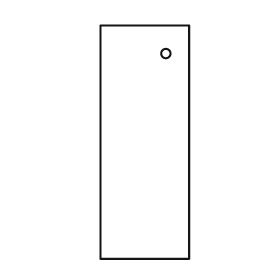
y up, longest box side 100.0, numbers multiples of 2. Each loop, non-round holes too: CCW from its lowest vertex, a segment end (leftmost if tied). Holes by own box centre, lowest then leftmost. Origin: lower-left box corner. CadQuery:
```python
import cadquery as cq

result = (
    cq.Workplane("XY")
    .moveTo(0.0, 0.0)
    .lineTo(38.0, 0.0)
    .lineTo(38.0, 100.0)
    .lineTo(0.0, 100.0)
    .close()
    .moveTo(28.0, 88.0)
    .circle(2.0)
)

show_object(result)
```